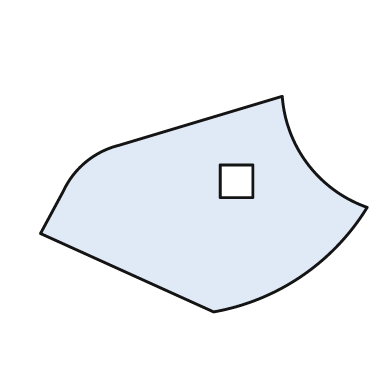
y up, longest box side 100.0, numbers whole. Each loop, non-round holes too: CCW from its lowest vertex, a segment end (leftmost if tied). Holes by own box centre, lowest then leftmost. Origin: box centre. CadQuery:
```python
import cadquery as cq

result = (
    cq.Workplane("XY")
    .moveTo(3.0, -33.0)
    .threePointArc((30.0, -22.0), (50.0, -1.0))
    .threePointArc((32.0, 12.0), (24.0, 33.0))
    .lineTo(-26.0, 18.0)
    .threePointArc((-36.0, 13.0), (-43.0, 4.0))
    .lineTo(-50.0, -9.0)
    .close()
    .moveTo(5.0, 2.0)
    .lineTo(15.0, 2.0)
    .lineTo(15.0, 12.0)
    .lineTo(5.0, 12.0)
    .close()
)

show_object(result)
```